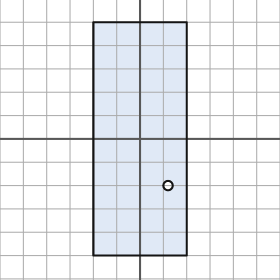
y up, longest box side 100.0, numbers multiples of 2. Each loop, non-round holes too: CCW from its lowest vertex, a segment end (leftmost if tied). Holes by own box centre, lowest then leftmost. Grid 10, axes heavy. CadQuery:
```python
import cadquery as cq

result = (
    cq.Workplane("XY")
    .moveTo(-20.0, -50.0)
    .lineTo(20.0, -50.0)
    .lineTo(20.0, 50.0)
    .lineTo(-20.0, 50.0)
    .close()
    .moveTo(12.0, -20.0)
    .circle(2.0)
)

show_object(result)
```